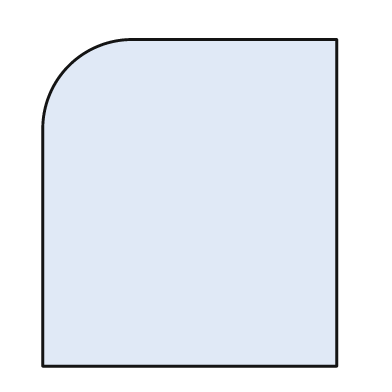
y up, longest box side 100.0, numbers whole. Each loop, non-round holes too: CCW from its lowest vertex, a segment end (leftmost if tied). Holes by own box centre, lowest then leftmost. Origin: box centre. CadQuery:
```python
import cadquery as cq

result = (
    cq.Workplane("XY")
    .moveTo(-45.0, -50.0)
    .lineTo(45.0, -50.0)
    .lineTo(45.0, 50.0)
    .lineTo(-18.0, 50.0)
    .threePointArc((-37.0, 42.0), (-45.0, 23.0))
    .close()
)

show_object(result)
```